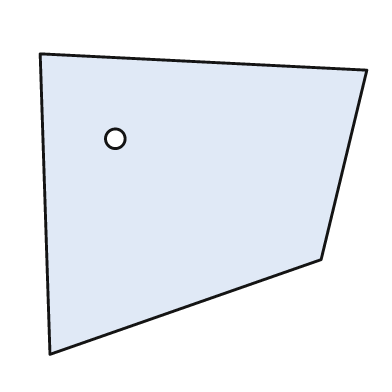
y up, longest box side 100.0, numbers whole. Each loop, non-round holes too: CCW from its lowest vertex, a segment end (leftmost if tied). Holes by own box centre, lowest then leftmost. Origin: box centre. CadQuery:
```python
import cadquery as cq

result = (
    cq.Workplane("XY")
    .moveTo(-47.0, -46.0)
    .lineTo(36.0, -17.0)
    .lineTo(50.0, 41.0)
    .lineTo(-50.0, 46.0)
    .close()
    .moveTo(-27.0, 20.0)
    .circle(3.0)
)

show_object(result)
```